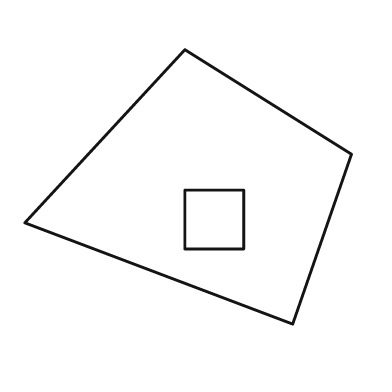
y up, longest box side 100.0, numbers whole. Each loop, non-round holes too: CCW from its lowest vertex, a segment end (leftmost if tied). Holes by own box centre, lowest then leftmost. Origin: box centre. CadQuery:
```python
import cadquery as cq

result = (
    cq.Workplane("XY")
    .moveTo(32.0, -42.0)
    .lineTo(50.0, 10.0)
    .lineTo(-1.0, 42.0)
    .lineTo(-50.0, -11.0)
    .close()
    .moveTo(-1.0, -19.0)
    .lineTo(17.0, -19.0)
    .lineTo(17.0, -1.0)
    .lineTo(-1.0, -1.0)
    .close()
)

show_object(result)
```